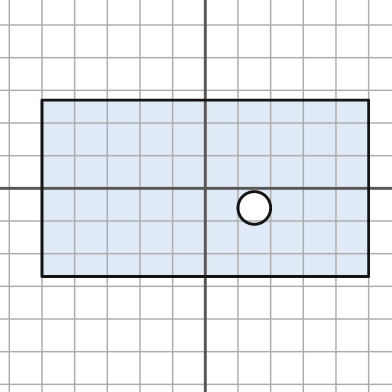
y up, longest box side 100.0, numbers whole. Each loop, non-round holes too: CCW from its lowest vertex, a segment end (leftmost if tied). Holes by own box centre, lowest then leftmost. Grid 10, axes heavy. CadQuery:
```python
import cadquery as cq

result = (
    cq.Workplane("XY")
    .moveTo(-50.0, -27.0)
    .lineTo(50.0, -27.0)
    .lineTo(50.0, 27.0)
    .lineTo(-50.0, 27.0)
    .close()
    .moveTo(15.0, -6.0)
    .circle(5.0)
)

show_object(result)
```